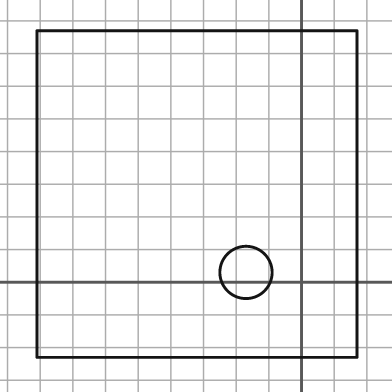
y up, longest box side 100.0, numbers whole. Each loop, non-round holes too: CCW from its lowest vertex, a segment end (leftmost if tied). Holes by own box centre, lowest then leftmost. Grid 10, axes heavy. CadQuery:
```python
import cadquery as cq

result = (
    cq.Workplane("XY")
    .moveTo(-81.0, -23.0)
    .lineTo(17.0, -23.0)
    .lineTo(17.0, 77.0)
    .lineTo(-81.0, 77.0)
    .close()
    .moveTo(-17.0, 3.0)
    .circle(8.0)
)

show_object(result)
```